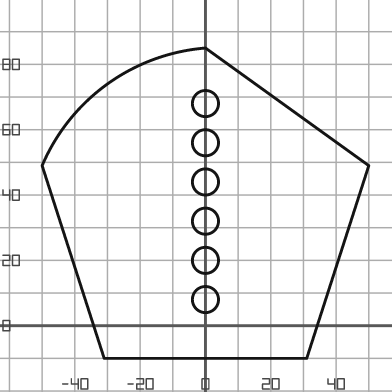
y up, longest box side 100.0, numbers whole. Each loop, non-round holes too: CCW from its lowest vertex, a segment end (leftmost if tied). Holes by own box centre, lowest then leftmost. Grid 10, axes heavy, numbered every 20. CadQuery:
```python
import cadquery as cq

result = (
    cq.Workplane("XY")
    .moveTo(-31.0, -10.0)
    .lineTo(31.0, -10.0)
    .lineTo(50.0, 49.0)
    .lineTo(0.0, 85.0)
    .threePointArc((-30.0, 74.0), (-50.0, 49.0))
    .close()
    .moveTo(0.0, 8.0)
    .circle(4.0)
    .moveTo(0.0, 20.0)
    .circle(4.0)
    .moveTo(0.0, 32.0)
    .circle(4.0)
    .moveTo(0.0, 44.0)
    .circle(4.0)
    .moveTo(0.0, 56.0)
    .circle(4.0)
    .moveTo(0.0, 68.0)
    .circle(4.0)
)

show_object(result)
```